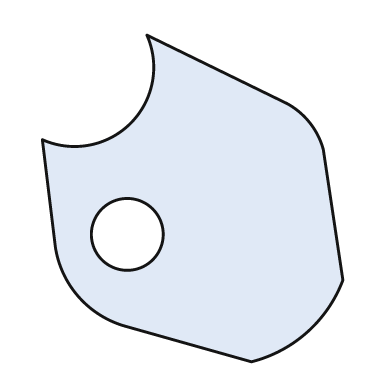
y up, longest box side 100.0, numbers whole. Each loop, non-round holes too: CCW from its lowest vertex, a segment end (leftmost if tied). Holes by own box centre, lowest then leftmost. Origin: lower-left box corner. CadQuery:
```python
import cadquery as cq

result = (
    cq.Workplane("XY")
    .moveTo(64.0, 0.0)
    .threePointArc((81.0, 9.0), (92.0, 25.0))
    .lineTo(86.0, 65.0)
    .threePointArc((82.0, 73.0), (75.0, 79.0))
    .lineTo(32.0, 100.0)
    .threePointArc((27.0, 73.0), (0.0, 68.0))
    .lineTo(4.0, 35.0)
    .threePointArc((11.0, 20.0), (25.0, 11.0))
    .close()
    .moveTo(26.0, 39.0)
    .circle(11.0)
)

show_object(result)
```